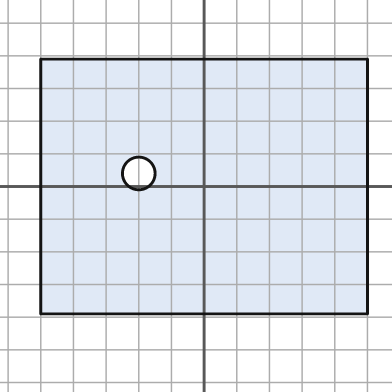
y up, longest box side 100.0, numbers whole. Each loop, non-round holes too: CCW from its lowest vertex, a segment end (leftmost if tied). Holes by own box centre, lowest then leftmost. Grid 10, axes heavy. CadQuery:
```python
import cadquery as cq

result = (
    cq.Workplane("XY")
    .moveTo(-50.0, -39.0)
    .lineTo(50.0, -39.0)
    .lineTo(50.0, 39.0)
    .lineTo(-50.0, 39.0)
    .close()
    .moveTo(-20.0, 4.0)
    .circle(5.0)
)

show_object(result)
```